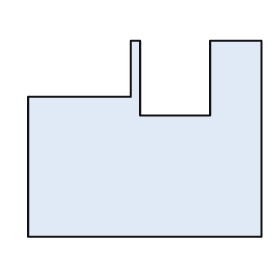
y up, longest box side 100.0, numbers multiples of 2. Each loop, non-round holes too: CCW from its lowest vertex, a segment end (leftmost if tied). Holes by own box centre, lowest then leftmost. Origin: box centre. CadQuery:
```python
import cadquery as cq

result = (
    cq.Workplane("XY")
    .moveTo(-50.0, -42.0)
    .lineTo(50.0, -42.0)
    .lineTo(50.0, 42.0)
    .lineTo(28.0, 42.0)
    .lineTo(28.0, 10.0)
    .lineTo(-2.0, 10.0)
    .lineTo(-2.0, 42.0)
    .lineTo(-6.0, 42.0)
    .lineTo(-6.0, 18.0)
    .lineTo(-50.0, 18.0)
    .close()
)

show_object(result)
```